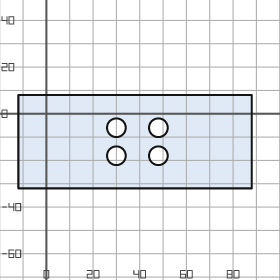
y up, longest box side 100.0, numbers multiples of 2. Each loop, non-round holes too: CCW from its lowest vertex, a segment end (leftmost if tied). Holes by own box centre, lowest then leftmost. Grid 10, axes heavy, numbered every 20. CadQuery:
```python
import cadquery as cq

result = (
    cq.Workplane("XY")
    .moveTo(-12.0, -32.0)
    .lineTo(88.0, -32.0)
    .lineTo(88.0, 8.0)
    .lineTo(-12.0, 8.0)
    .close()
    .moveTo(30.0, -18.0)
    .circle(4.0)
    .moveTo(48.0, -18.0)
    .circle(4.0)
    .moveTo(30.0, -6.0)
    .circle(4.0)
    .moveTo(48.0, -6.0)
    .circle(4.0)
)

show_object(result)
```